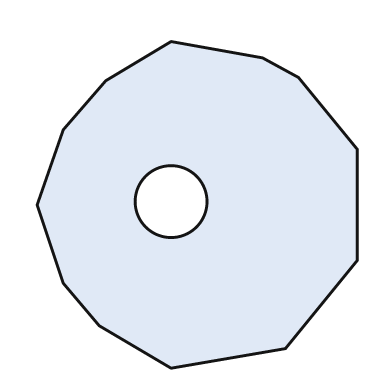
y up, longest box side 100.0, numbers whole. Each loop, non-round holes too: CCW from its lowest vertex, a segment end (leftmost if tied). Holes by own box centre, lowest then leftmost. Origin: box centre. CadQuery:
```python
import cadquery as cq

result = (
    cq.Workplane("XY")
    .moveTo(-8.0, -50.0)
    .lineTo(27.0, -44.0)
    .lineTo(49.0, -17.0)
    .lineTo(49.0, 17.0)
    .lineTo(31.0, 39.0)
    .lineTo(20.0, 45.0)
    .lineTo(-8.0, 50.0)
    .lineTo(-28.0, 38.0)
    .lineTo(-41.0, 23.0)
    .lineTo(-49.0, 0.0)
    .lineTo(-41.0, -24.0)
    .lineTo(-30.0, -37.0)
    .close()
    .moveTo(-8.0, 1.0)
    .circle(11.0)
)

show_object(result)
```